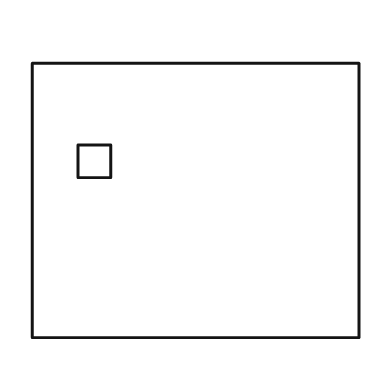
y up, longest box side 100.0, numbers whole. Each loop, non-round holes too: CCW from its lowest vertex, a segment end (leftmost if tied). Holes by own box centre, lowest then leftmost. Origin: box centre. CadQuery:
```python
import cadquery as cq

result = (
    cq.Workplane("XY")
    .moveTo(-50.0, -42.0)
    .lineTo(50.0, -42.0)
    .lineTo(50.0, 42.0)
    .lineTo(-50.0, 42.0)
    .close()
    .moveTo(-36.0, 7.0)
    .lineTo(-26.0, 7.0)
    .lineTo(-26.0, 17.0)
    .lineTo(-36.0, 17.0)
    .close()
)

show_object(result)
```